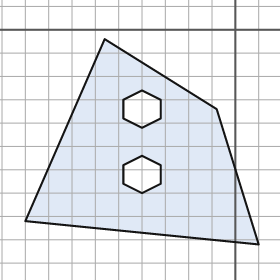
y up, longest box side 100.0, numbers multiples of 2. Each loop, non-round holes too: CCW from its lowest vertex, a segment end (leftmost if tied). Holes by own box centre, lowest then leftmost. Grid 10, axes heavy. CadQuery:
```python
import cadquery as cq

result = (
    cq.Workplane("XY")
    .moveTo(10.0, -92.0)
    .lineTo(-8.0, -34.0)
    .lineTo(-56.0, -4.0)
    .lineTo(-90.0, -82.0)
    .close()
    .moveTo(-40.0, -70.0)
    .lineTo(-32.0, -66.0)
    .lineTo(-32.0, -58.0)
    .lineTo(-40.0, -54.0)
    .lineTo(-48.0, -58.0)
    .lineTo(-48.0, -66.0)
    .close()
    .moveTo(-40.0, -42.0)
    .lineTo(-32.0, -38.0)
    .lineTo(-32.0, -30.0)
    .lineTo(-40.0, -26.0)
    .lineTo(-48.0, -30.0)
    .lineTo(-48.0, -38.0)
    .close()
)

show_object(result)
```